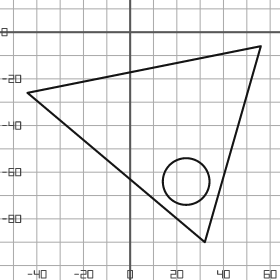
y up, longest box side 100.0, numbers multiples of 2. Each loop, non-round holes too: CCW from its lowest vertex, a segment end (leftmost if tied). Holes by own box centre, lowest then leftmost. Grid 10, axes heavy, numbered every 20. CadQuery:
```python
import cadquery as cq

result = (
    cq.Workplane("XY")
    .moveTo(32.0, -90.0)
    .lineTo(56.0, -6.0)
    .lineTo(-44.0, -26.0)
    .close()
    .moveTo(24.0, -64.0)
    .circle(10.0)
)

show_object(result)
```